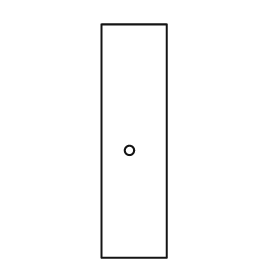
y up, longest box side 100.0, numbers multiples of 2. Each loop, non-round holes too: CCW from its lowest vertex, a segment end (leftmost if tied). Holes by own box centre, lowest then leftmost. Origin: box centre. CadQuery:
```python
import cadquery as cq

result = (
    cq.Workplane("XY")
    .moveTo(-14.0, -50.0)
    .lineTo(14.0, -50.0)
    .lineTo(14.0, 50.0)
    .lineTo(-14.0, 50.0)
    .close()
    .moveTo(-2.0, -4.0)
    .circle(2.0)
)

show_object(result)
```